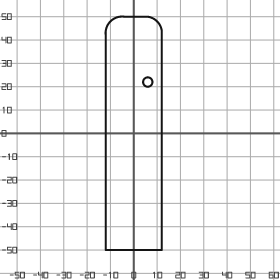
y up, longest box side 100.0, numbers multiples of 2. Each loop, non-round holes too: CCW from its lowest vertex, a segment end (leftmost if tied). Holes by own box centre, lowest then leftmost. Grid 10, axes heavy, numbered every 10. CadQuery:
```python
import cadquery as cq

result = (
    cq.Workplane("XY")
    .moveTo(-12.0, -50.0)
    .lineTo(12.0, -50.0)
    .lineTo(12.0, 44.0)
    .threePointArc((10.0, 48.0), (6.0, 50.0))
    .lineTo(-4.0, 50.0)
    .threePointArc((-10.0, 48.0), (-12.0, 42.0))
    .close()
    .moveTo(6.0, 22.0)
    .circle(2.0)
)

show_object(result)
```